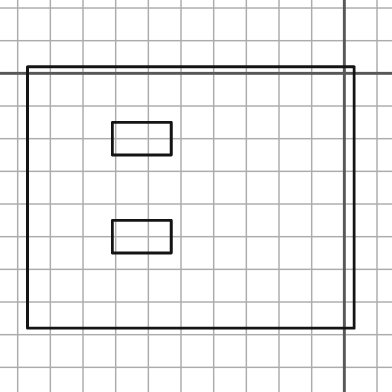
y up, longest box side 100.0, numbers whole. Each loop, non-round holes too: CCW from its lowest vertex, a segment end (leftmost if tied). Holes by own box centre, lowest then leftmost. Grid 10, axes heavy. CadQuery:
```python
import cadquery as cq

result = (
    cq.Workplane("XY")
    .moveTo(-97.0, -78.0)
    .lineTo(3.0, -78.0)
    .lineTo(3.0, 2.0)
    .lineTo(-97.0, 2.0)
    .close()
    .moveTo(-71.0, -55.0)
    .lineTo(-53.0, -55.0)
    .lineTo(-53.0, -45.0)
    .lineTo(-71.0, -45.0)
    .close()
    .moveTo(-71.0, -25.0)
    .lineTo(-53.0, -25.0)
    .lineTo(-53.0, -15.0)
    .lineTo(-71.0, -15.0)
    .close()
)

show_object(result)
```